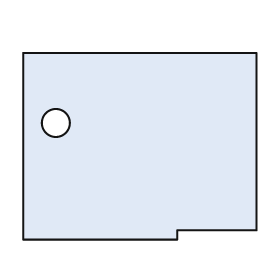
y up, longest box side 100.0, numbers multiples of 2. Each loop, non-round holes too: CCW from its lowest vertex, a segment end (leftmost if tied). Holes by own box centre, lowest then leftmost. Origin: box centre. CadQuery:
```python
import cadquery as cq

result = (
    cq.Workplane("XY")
    .moveTo(-50.0, -40.0)
    .lineTo(16.0, -40.0)
    .lineTo(16.0, -36.0)
    .lineTo(50.0, -36.0)
    .lineTo(50.0, 40.0)
    .lineTo(-50.0, 40.0)
    .close()
    .moveTo(-36.0, 10.0)
    .circle(6.0)
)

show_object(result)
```